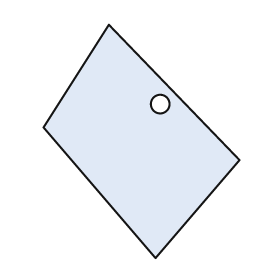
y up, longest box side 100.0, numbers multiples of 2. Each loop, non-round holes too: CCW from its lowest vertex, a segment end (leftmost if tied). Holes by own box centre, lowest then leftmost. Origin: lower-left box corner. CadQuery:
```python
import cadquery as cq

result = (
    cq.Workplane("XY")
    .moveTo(48.0, 0.0)
    .lineTo(84.0, 42.0)
    .lineTo(28.0, 100.0)
    .lineTo(0.0, 56.0)
    .close()
    .moveTo(50.0, 66.0)
    .circle(4.0)
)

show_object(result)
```